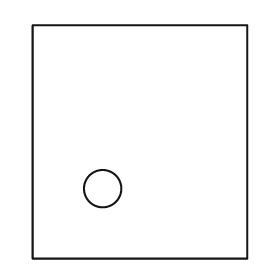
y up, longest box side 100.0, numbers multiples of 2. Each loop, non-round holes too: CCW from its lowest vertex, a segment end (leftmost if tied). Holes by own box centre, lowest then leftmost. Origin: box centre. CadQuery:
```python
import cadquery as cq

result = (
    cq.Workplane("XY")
    .moveTo(-46.0, -50.0)
    .lineTo(46.0, -50.0)
    .lineTo(46.0, 50.0)
    .lineTo(-46.0, 50.0)
    .close()
    .moveTo(-16.0, -20.0)
    .circle(8.0)
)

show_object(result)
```